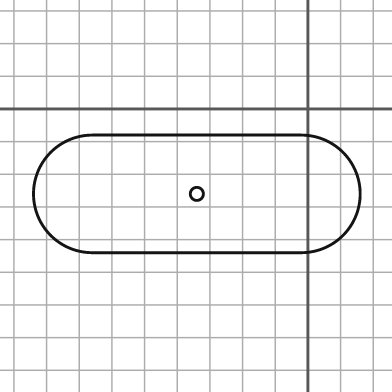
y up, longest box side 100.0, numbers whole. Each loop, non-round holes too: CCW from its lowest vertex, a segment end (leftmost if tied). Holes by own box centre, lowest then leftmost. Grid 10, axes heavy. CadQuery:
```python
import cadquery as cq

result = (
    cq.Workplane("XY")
    .moveTo(-66.0, -44.0)
    .lineTo(-2.0, -44.0)
    .threePointArc((16.0, -26.0), (-2.0, -8.0))
    .lineTo(-66.0, -8.0)
    .threePointArc((-84.0, -26.0), (-66.0, -44.0))
    .close()
    .moveTo(-34.0, -26.0)
    .circle(2.0)
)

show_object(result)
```